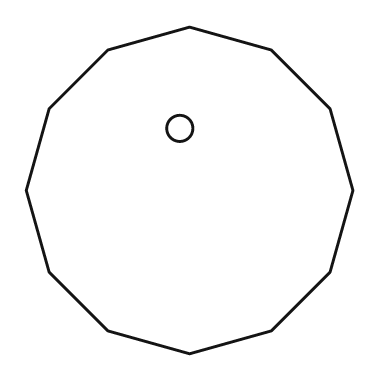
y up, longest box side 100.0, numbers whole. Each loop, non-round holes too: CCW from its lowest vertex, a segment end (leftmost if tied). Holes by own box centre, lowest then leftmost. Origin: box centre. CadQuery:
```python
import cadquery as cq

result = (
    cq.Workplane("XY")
    .moveTo(0.0, -50.0)
    .lineTo(25.0, -43.0)
    .lineTo(43.0, -25.0)
    .lineTo(50.0, 0.0)
    .lineTo(43.0, 25.0)
    .lineTo(25.0, 43.0)
    .lineTo(0.0, 50.0)
    .lineTo(-25.0, 43.0)
    .lineTo(-43.0, 25.0)
    .lineTo(-50.0, 0.0)
    .lineTo(-43.0, -25.0)
    .lineTo(-25.0, -43.0)
    .close()
    .moveTo(-3.0, 19.0)
    .circle(4.0)
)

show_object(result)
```